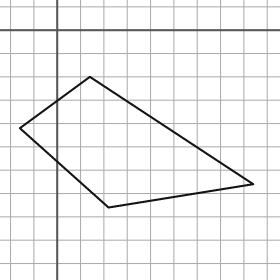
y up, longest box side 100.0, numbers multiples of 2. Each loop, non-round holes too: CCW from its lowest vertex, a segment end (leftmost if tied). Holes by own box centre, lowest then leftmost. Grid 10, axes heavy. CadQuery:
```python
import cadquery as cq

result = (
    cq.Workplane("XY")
    .moveTo(22.0, -76.0)
    .lineTo(84.0, -66.0)
    .lineTo(14.0, -20.0)
    .lineTo(-16.0, -42.0)
    .close()
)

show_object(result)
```